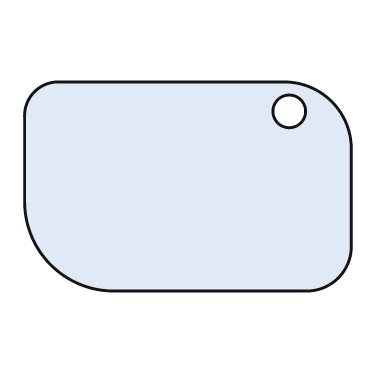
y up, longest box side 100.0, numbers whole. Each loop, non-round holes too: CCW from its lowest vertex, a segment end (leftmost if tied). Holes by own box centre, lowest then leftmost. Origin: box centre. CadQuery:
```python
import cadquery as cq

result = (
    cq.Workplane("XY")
    .moveTo(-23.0, -32.0)
    .lineTo(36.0, -32.0)
    .threePointArc((46.0, -28.0), (50.0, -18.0))
    .lineTo(50.0, 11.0)
    .threePointArc((44.0, 26.0), (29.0, 32.0))
    .lineTo(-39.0, 32.0)
    .threePointArc((-47.0, 29.0), (-50.0, 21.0))
    .lineTo(-50.0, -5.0)
    .threePointArc((-42.0, -24.0), (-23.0, -32.0))
    .close()
    .moveTo(31.0, 23.0)
    .circle(5.0)
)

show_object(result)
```